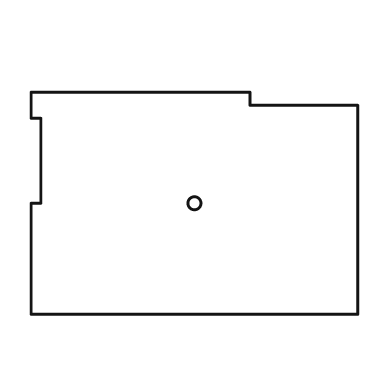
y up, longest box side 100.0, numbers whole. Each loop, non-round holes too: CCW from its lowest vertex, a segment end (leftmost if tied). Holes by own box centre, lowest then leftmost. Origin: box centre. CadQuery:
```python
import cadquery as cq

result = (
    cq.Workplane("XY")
    .moveTo(-50.0, -34.0)
    .lineTo(50.0, -34.0)
    .lineTo(50.0, 30.0)
    .lineTo(17.0, 30.0)
    .lineTo(17.0, 34.0)
    .lineTo(-50.0, 34.0)
    .lineTo(-50.0, 26.0)
    .lineTo(-47.0, 26.0)
    .lineTo(-47.0, 0.0)
    .lineTo(-50.0, 0.0)
    .close()
    .moveTo(0.0, 0.0)
    .circle(2.0)
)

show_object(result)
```